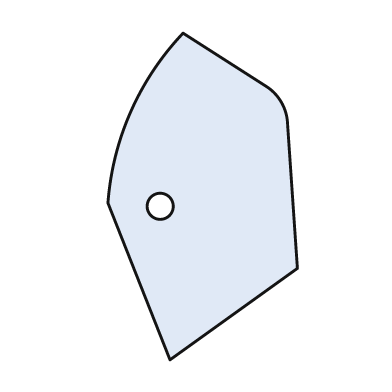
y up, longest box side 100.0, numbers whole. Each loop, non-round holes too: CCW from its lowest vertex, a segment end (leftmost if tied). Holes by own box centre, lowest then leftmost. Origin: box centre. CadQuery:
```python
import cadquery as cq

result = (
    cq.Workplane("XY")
    .moveTo(-10.0, -50.0)
    .lineTo(29.0, -22.0)
    .lineTo(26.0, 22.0)
    .threePointArc((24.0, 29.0), (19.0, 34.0))
    .lineTo(-6.0, 50.0)
    .threePointArc((-22.0, 26.0), (-29.0, -2.0))
    .close()
    .moveTo(-13.0, -3.0)
    .circle(4.0)
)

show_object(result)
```